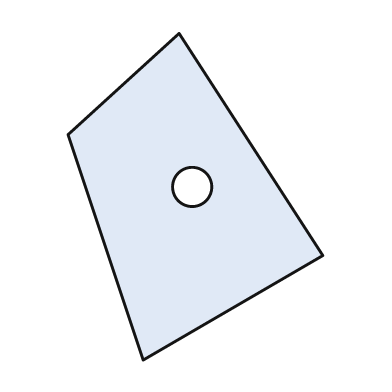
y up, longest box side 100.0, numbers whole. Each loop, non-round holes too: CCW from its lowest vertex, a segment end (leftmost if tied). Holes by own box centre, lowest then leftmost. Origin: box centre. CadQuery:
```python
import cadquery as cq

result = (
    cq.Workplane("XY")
    .moveTo(-16.0, -50.0)
    .lineTo(39.0, -18.0)
    .lineTo(-5.0, 50.0)
    .lineTo(-39.0, 19.0)
    .close()
    .moveTo(-1.0, 3.0)
    .circle(6.0)
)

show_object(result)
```